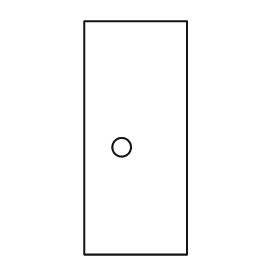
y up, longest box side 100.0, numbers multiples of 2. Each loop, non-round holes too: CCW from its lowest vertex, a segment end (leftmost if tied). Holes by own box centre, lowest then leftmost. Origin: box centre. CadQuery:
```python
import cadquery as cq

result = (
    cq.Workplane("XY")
    .moveTo(-22.0, -50.0)
    .lineTo(22.0, -50.0)
    .lineTo(22.0, 50.0)
    .lineTo(-22.0, 50.0)
    .close()
    .moveTo(-6.0, -4.0)
    .circle(4.0)
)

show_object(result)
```